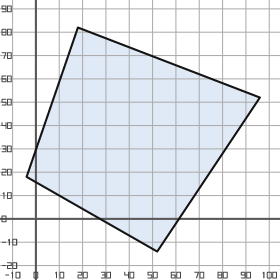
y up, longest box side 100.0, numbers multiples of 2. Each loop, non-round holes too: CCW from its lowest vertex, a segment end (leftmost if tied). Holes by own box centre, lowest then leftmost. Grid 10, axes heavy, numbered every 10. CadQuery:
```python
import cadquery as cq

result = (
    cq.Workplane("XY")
    .moveTo(52.0, -14.0)
    .lineTo(96.0, 52.0)
    .lineTo(18.0, 82.0)
    .lineTo(-4.0, 18.0)
    .close()
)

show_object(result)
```